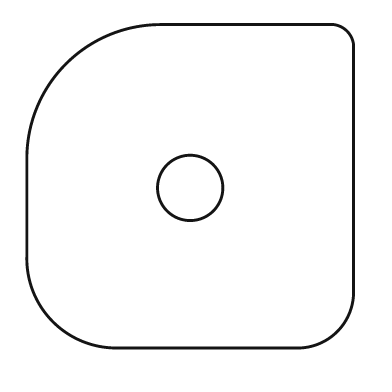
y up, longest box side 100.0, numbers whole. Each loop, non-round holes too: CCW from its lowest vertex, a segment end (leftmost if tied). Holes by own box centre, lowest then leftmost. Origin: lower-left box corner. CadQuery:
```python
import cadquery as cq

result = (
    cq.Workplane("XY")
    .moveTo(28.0, 0.0)
    .lineTo(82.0, 0.0)
    .threePointArc((95.0, 5.0), (100.0, 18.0))
    .lineTo(100.0, 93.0)
    .threePointArc((98.0, 97.0), (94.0, 99.0))
    .lineTo(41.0, 99.0)
    .threePointArc((12.0, 87.0), (0.0, 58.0))
    .lineTo(0.0, 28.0)
    .threePointArc((8.0, 8.0), (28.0, 0.0))
    .close()
    .moveTo(50.0, 49.0)
    .circle(10.0)
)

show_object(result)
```